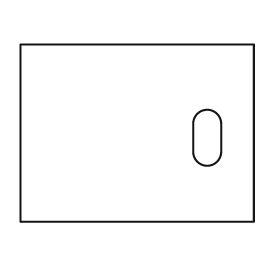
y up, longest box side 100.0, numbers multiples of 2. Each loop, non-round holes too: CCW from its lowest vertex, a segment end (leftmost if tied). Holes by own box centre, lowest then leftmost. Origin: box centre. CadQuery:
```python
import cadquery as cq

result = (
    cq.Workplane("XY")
    .moveTo(-50.0, -38.0)
    .lineTo(50.0, -38.0)
    .lineTo(50.0, 38.0)
    .lineTo(-50.0, 38.0)
    .close()
    .moveTo(24.0, -8.0)
    .threePointArc((30.0, -14.0), (36.0, -8.0))
    .lineTo(36.0, 4.0)
    .threePointArc((30.0, 10.0), (24.0, 4.0))
    .close()
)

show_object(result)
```